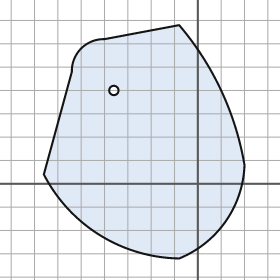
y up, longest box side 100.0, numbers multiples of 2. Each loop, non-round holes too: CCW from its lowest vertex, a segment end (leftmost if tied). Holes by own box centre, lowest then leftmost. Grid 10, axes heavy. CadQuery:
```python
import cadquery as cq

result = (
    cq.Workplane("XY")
    .moveTo(-8.0, -32.0)
    .threePointArc((12.0, -16.0), (20.0, 8.0))
    .threePointArc((10.0, 40.0), (-8.0, 68.0))
    .lineTo(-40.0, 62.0)
    .threePointArc((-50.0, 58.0), (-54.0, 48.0))
    .lineTo(-66.0, 4.0)
    .threePointArc((-42.0, -22.0), (-8.0, -32.0))
    .close()
    .moveTo(-36.0, 40.0)
    .circle(2.0)
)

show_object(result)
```